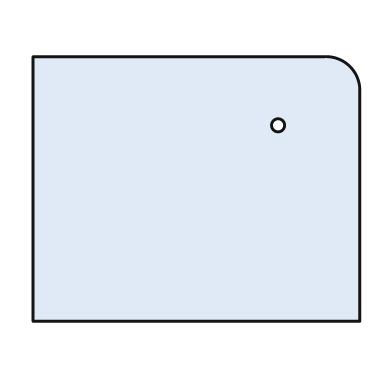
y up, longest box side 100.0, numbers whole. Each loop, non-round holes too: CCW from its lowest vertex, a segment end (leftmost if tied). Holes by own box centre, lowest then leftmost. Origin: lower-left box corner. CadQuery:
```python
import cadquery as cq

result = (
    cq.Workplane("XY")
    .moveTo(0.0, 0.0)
    .lineTo(100.0, 0.0)
    .lineTo(100.0, 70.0)
    .threePointArc((97.0, 78.0), (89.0, 81.0))
    .lineTo(0.0, 81.0)
    .close()
    .moveTo(75.0, 60.0)
    .circle(2.0)
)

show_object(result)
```